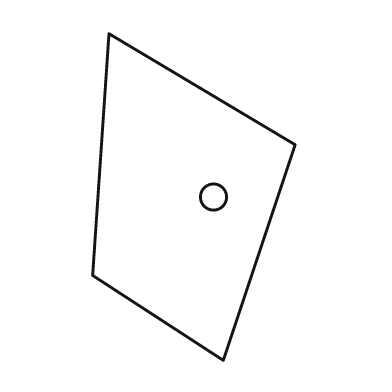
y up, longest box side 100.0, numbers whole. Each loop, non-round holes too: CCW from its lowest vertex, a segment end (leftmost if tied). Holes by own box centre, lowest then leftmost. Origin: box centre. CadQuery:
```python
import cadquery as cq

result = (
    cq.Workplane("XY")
    .moveTo(9.0, -50.0)
    .lineTo(31.0, 16.0)
    .lineTo(-26.0, 50.0)
    .lineTo(-31.0, -24.0)
    .close()
    .moveTo(6.0, 0.0)
    .circle(4.0)
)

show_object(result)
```